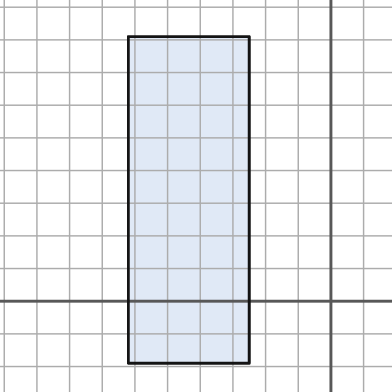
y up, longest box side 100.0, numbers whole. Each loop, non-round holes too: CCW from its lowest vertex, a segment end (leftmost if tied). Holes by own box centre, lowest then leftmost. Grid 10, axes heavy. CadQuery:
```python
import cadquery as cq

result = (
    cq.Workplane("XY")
    .moveTo(-62.0, -19.0)
    .lineTo(-25.0, -19.0)
    .lineTo(-25.0, 81.0)
    .lineTo(-62.0, 81.0)
    .close()
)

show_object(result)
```